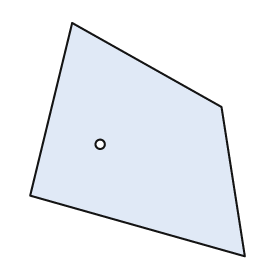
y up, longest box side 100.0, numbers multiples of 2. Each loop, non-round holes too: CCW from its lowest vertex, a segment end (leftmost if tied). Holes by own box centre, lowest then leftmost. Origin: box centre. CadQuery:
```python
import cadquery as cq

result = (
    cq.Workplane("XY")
    .moveTo(46.0, -50.0)
    .lineTo(36.0, 14.0)
    .lineTo(-28.0, 50.0)
    .lineTo(-46.0, -24.0)
    .close()
    .moveTo(-16.0, -2.0)
    .circle(2.0)
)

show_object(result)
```